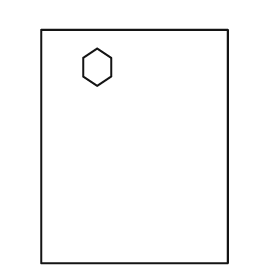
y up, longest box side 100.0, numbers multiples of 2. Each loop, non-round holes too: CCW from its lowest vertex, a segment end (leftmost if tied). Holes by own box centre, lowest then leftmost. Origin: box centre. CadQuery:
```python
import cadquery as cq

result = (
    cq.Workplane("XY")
    .moveTo(-40.0, -50.0)
    .lineTo(40.0, -50.0)
    .lineTo(40.0, 50.0)
    .lineTo(-40.0, 50.0)
    .close()
    .moveTo(-16.0, 26.0)
    .lineTo(-10.0, 30.0)
    .lineTo(-10.0, 38.0)
    .lineTo(-16.0, 42.0)
    .lineTo(-22.0, 38.0)
    .lineTo(-22.0, 30.0)
    .close()
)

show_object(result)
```